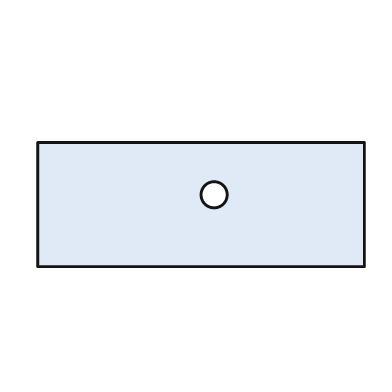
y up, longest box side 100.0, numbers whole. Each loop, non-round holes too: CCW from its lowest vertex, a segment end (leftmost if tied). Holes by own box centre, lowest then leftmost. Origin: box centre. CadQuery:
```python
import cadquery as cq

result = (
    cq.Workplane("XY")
    .moveTo(-50.0, -19.0)
    .lineTo(50.0, -19.0)
    .lineTo(50.0, 19.0)
    .lineTo(-50.0, 19.0)
    .close()
    .moveTo(4.0, 3.0)
    .circle(4.0)
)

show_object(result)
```